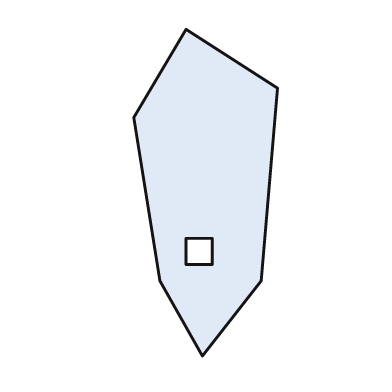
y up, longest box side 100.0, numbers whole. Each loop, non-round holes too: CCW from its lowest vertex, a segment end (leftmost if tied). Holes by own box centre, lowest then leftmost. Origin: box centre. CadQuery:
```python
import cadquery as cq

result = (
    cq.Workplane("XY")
    .moveTo(-1.0, -50.0)
    .lineTo(17.0, -27.0)
    .lineTo(22.0, 32.0)
    .lineTo(-6.0, 50.0)
    .lineTo(-22.0, 23.0)
    .lineTo(-14.0, -27.0)
    .close()
    .moveTo(-6.0, -22.0)
    .lineTo(2.0, -22.0)
    .lineTo(2.0, -14.0)
    .lineTo(-6.0, -14.0)
    .close()
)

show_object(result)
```